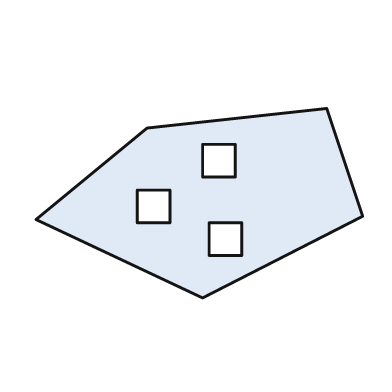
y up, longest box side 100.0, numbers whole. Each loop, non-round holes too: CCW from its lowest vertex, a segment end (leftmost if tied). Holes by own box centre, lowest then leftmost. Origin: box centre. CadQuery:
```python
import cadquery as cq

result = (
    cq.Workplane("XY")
    .moveTo(1.0, -29.0)
    .lineTo(50.0, -4.0)
    .lineTo(39.0, 29.0)
    .lineTo(-16.0, 23.0)
    .lineTo(-50.0, -5.0)
    .close()
    .moveTo(3.0, -16.0)
    .lineTo(13.0, -16.0)
    .lineTo(13.0, -6.0)
    .lineTo(3.0, -6.0)
    .close()
    .moveTo(-19.0, -6.0)
    .lineTo(-9.0, -6.0)
    .lineTo(-9.0, 4.0)
    .lineTo(-19.0, 4.0)
    .close()
    .moveTo(1.0, 8.0)
    .lineTo(11.0, 8.0)
    .lineTo(11.0, 18.0)
    .lineTo(1.0, 18.0)
    .close()
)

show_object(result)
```